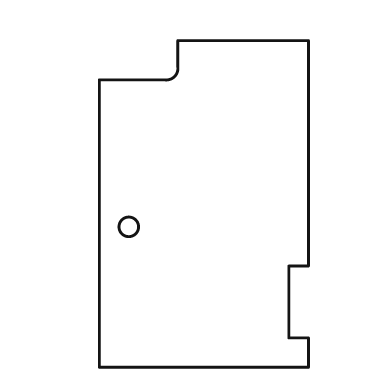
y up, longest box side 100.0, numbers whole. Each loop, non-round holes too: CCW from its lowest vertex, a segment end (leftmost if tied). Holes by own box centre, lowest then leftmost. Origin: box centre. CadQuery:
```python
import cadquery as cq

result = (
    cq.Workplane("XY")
    .moveTo(-32.0, -50.0)
    .lineTo(32.0, -50.0)
    .lineTo(32.0, -41.0)
    .lineTo(26.0, -41.0)
    .lineTo(26.0, -19.0)
    .lineTo(32.0, -19.0)
    .lineTo(32.0, 50.0)
    .lineTo(-8.0, 50.0)
    .lineTo(-8.0, 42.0)
    .threePointArc((-9.0, 39.0), (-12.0, 38.0))
    .lineTo(-32.0, 38.0)
    .close()
    .moveTo(-23.0, -7.0)
    .circle(3.0)
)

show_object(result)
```